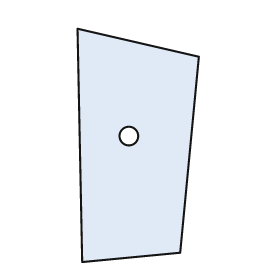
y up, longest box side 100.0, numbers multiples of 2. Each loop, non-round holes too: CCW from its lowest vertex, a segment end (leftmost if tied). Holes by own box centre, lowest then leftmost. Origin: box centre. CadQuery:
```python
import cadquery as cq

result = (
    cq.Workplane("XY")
    .moveTo(-24.0, -50.0)
    .lineTo(18.0, -46.0)
    .lineTo(26.0, 38.0)
    .lineTo(-26.0, 50.0)
    .close()
    .moveTo(-4.0, 4.0)
    .circle(4.0)
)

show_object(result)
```